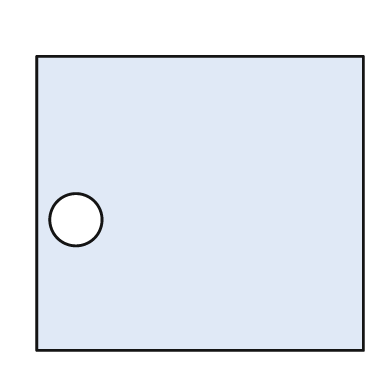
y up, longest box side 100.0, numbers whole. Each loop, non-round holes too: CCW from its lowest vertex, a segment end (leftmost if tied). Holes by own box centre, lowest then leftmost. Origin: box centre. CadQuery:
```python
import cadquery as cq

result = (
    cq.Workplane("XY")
    .moveTo(-50.0, -45.0)
    .lineTo(50.0, -45.0)
    .lineTo(50.0, 45.0)
    .lineTo(-50.0, 45.0)
    .close()
    .moveTo(-38.0, -5.0)
    .circle(8.0)
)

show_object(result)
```